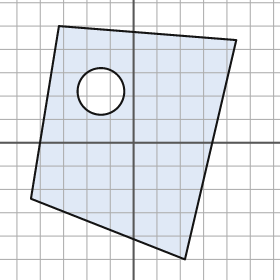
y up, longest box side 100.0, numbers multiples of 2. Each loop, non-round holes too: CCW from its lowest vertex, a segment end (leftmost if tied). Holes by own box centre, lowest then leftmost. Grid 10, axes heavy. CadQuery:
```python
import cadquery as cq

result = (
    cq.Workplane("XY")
    .moveTo(22.0, -50.0)
    .lineTo(44.0, 44.0)
    .lineTo(-32.0, 50.0)
    .lineTo(-44.0, -24.0)
    .close()
    .moveTo(-14.0, 22.0)
    .circle(10.0)
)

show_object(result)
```